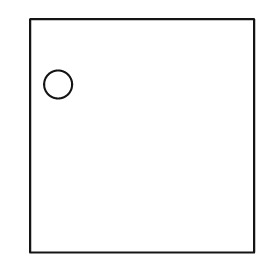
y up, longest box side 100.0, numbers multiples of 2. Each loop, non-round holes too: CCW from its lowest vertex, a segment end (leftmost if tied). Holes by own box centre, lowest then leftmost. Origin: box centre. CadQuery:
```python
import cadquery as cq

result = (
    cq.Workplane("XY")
    .moveTo(-48.0, -50.0)
    .lineTo(48.0, -50.0)
    .lineTo(48.0, 50.0)
    .lineTo(-48.0, 50.0)
    .close()
    .moveTo(-36.0, 22.0)
    .circle(6.0)
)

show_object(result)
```